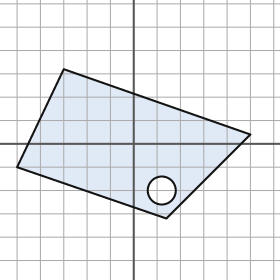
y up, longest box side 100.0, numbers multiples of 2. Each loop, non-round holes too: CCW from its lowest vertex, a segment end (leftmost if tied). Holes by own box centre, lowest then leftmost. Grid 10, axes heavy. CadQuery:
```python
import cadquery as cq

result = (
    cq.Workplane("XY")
    .moveTo(14.0, -32.0)
    .lineTo(50.0, 4.0)
    .lineTo(-30.0, 32.0)
    .lineTo(-50.0, -10.0)
    .close()
    .moveTo(12.0, -20.0)
    .circle(6.0)
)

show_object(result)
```